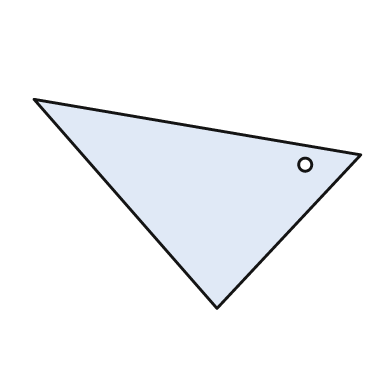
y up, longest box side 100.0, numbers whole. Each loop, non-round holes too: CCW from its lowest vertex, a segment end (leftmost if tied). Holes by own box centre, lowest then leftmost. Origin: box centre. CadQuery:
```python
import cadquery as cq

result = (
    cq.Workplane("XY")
    .moveTo(6.0, -32.0)
    .lineTo(50.0, 15.0)
    .lineTo(-50.0, 32.0)
    .close()
    .moveTo(33.0, 12.0)
    .circle(2.0)
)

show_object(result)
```